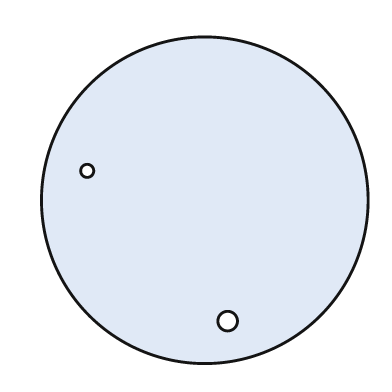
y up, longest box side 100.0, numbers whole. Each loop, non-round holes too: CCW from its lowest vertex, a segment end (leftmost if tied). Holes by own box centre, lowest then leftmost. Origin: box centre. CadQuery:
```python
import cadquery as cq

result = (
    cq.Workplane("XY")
    .moveTo(0.0, 0.0)
    .circle(50.0)
    .moveTo(7.0, -37.0)
    .circle(3.0)
    .moveTo(-36.0, 9.0)
    .circle(2.0)
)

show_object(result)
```